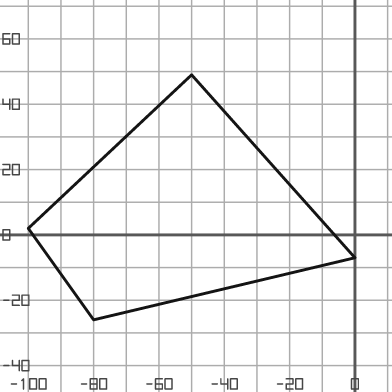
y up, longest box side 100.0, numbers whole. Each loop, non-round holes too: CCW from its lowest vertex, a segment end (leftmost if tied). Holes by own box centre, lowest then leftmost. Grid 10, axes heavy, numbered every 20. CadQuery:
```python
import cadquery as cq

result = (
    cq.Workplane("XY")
    .moveTo(-80.0, -26.0)
    .lineTo(0.0, -7.0)
    .lineTo(-50.0, 49.0)
    .lineTo(-100.0, 2.0)
    .close()
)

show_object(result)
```